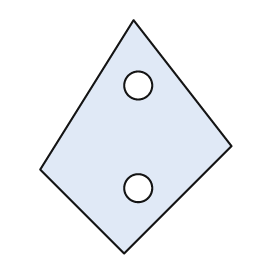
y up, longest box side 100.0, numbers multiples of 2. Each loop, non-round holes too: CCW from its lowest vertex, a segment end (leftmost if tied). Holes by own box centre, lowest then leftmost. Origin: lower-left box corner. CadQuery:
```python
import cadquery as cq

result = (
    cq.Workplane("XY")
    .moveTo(36.0, 0.0)
    .lineTo(82.0, 46.0)
    .lineTo(40.0, 100.0)
    .lineTo(0.0, 36.0)
    .close()
    .moveTo(42.0, 28.0)
    .circle(6.0)
    .moveTo(42.0, 72.0)
    .circle(6.0)
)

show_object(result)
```